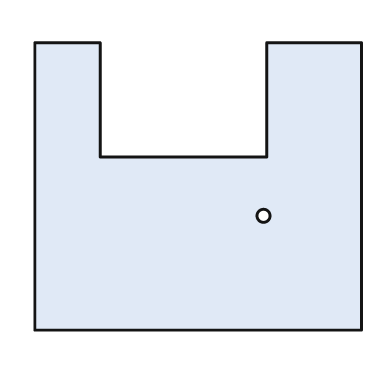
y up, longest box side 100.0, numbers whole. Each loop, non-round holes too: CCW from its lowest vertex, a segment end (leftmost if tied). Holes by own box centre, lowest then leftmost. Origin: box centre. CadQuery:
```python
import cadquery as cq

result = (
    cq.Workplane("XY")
    .moveTo(-50.0, -44.0)
    .lineTo(50.0, -44.0)
    .lineTo(50.0, 44.0)
    .lineTo(21.0, 44.0)
    .lineTo(21.0, 9.0)
    .lineTo(-30.0, 9.0)
    .lineTo(-30.0, 44.0)
    .lineTo(-50.0, 44.0)
    .close()
    .moveTo(20.0, -9.0)
    .circle(2.0)
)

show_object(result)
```